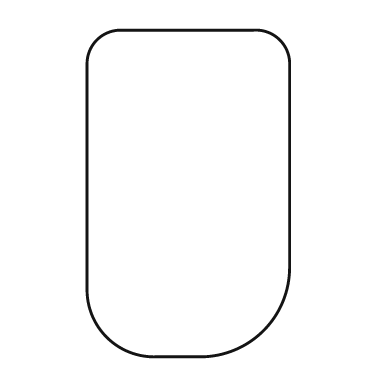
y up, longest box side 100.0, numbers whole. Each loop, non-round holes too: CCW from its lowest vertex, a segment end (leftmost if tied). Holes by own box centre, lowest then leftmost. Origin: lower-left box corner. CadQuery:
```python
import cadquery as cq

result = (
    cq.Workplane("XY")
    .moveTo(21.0, 0.0)
    .lineTo(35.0, 0.0)
    .threePointArc((54.0, 8.0), (62.0, 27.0))
    .lineTo(62.0, 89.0)
    .threePointArc((59.0, 97.0), (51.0, 100.0))
    .lineTo(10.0, 100.0)
    .threePointArc((3.0, 97.0), (0.0, 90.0))
    .lineTo(0.0, 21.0)
    .threePointArc((6.0, 6.0), (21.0, 0.0))
    .close()
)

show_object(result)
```